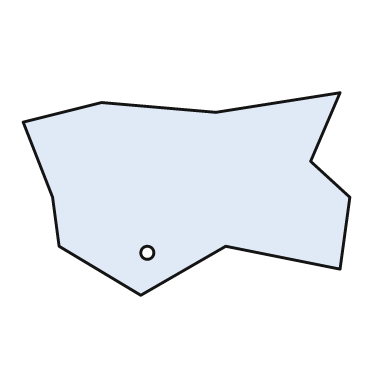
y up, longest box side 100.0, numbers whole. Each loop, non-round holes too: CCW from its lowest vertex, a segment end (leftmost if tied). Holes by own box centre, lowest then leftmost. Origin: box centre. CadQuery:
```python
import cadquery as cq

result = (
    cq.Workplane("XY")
    .moveTo(-14.0, -31.0)
    .lineTo(12.0, -16.0)
    .lineTo(47.0, -23.0)
    .lineTo(50.0, -1.0)
    .lineTo(38.0, 10.0)
    .lineTo(47.0, 31.0)
    .lineTo(9.0, 25.0)
    .lineTo(-26.0, 28.0)
    .lineTo(-50.0, 22.0)
    .lineTo(-41.0, -1.0)
    .lineTo(-39.0, -16.0)
    .close()
    .moveTo(-12.0, -18.0)
    .circle(2.0)
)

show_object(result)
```